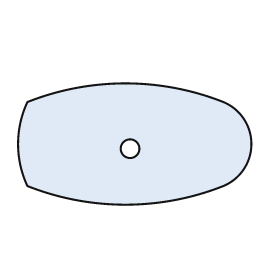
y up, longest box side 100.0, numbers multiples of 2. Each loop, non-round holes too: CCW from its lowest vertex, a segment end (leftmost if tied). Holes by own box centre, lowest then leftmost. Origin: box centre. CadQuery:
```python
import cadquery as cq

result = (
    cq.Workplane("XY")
    .moveTo(-46.0, -18.0)
    .threePointArc((-4.0, -26.0), (38.0, -18.0))
    .threePointArc((50.0, 0.0), (38.0, 18.0))
    .threePointArc((-4.0, 26.0), (-46.0, 18.0))
    .threePointArc((-50.0, 0.0), (-46.0, -18.0))
    .close()
    .moveTo(-2.0, -2.0)
    .circle(4.0)
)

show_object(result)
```